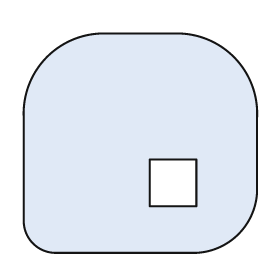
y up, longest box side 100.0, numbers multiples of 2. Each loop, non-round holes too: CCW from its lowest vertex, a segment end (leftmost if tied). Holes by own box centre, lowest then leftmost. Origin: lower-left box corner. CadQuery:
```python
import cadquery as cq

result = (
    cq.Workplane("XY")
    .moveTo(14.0, 0.0)
    .lineTo(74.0, 0.0)
    .threePointArc((92.0, 8.0), (100.0, 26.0))
    .lineTo(100.0, 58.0)
    .threePointArc((90.0, 84.0), (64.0, 94.0))
    .lineTo(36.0, 94.0)
    .threePointArc((10.0, 84.0), (0.0, 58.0))
    .lineTo(0.0, 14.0)
    .threePointArc((4.0, 4.0), (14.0, 0.0))
    .close()
    .moveTo(54.0, 20.0)
    .lineTo(74.0, 20.0)
    .lineTo(74.0, 40.0)
    .lineTo(54.0, 40.0)
    .close()
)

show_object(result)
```